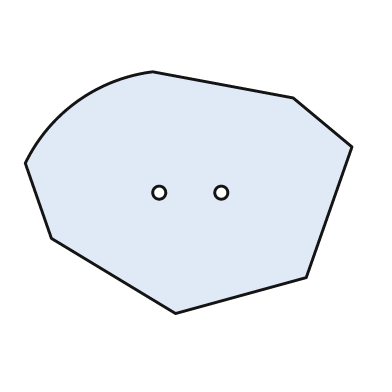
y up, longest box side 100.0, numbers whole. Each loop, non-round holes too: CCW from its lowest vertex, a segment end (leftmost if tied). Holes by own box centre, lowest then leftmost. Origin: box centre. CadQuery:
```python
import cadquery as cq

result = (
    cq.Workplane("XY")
    .moveTo(-4.0, -37.0)
    .lineTo(36.0, -26.0)
    .lineTo(50.0, 14.0)
    .lineTo(32.0, 29.0)
    .lineTo(-11.0, 37.0)
    .threePointArc((-34.0, 28.0), (-50.0, 9.0))
    .lineTo(-42.0, -14.0)
    .close()
    .moveTo(-9.0, 0.0)
    .circle(2.0)
    .moveTo(10.0, 0.0)
    .circle(2.0)
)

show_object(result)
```